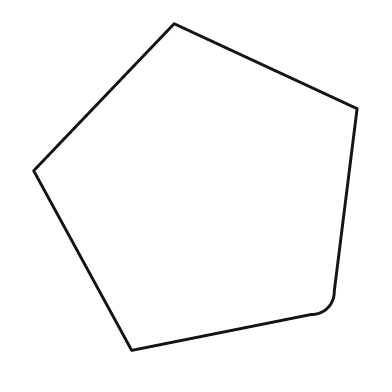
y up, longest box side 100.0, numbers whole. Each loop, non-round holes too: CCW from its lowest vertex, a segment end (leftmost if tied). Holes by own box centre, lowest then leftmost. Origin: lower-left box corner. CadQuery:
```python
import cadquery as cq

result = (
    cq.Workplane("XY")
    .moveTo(30.0, 0.0)
    .lineTo(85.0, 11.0)
    .threePointArc((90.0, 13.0), (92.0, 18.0))
    .lineTo(99.0, 74.0)
    .lineTo(43.0, 100.0)
    .lineTo(0.0, 55.0)
    .close()
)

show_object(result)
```